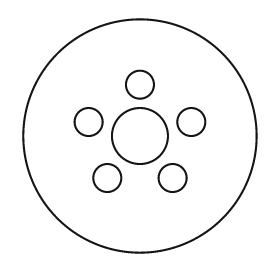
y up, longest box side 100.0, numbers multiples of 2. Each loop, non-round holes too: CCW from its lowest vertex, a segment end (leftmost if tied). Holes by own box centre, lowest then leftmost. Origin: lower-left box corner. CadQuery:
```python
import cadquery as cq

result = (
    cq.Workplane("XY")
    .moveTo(50.0, 50.0)
    .circle(50.0)
    .moveTo(36.0, 32.0)
    .circle(6.0)
    .moveTo(64.0, 32.0)
    .circle(6.0)
    .moveTo(50.0, 50.0)
    .circle(12.0)
    .moveTo(28.0, 56.0)
    .circle(6.0)
    .moveTo(72.0, 56.0)
    .circle(6.0)
    .moveTo(50.0, 72.0)
    .circle(6.0)
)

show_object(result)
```